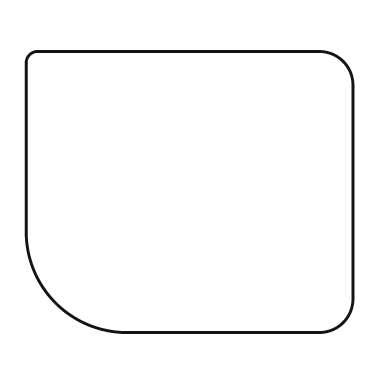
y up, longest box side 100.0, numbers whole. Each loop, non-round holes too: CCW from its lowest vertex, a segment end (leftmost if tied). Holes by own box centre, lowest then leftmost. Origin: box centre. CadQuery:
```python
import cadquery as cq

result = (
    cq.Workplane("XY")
    .moveTo(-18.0, -43.0)
    .lineTo(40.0, -43.0)
    .threePointArc((47.0, -40.0), (50.0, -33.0))
    .lineTo(50.0, 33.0)
    .threePointArc((47.0, 40.0), (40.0, 43.0))
    .lineTo(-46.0, 43.0)
    .threePointArc((-49.0, 42.0), (-50.0, 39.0))
    .lineTo(-50.0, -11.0)
    .threePointArc((-41.0, -34.0), (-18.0, -43.0))
    .close()
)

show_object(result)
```